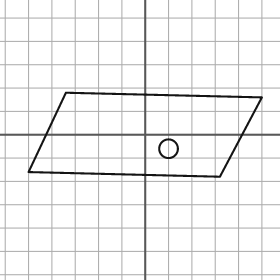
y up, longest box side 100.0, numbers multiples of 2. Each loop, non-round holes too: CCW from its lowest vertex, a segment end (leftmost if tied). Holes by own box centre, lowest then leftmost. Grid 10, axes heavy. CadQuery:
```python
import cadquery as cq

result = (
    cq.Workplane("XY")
    .moveTo(32.0, -18.0)
    .lineTo(50.0, 16.0)
    .lineTo(-34.0, 18.0)
    .lineTo(-50.0, -16.0)
    .close()
    .moveTo(10.0, -6.0)
    .circle(4.0)
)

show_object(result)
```